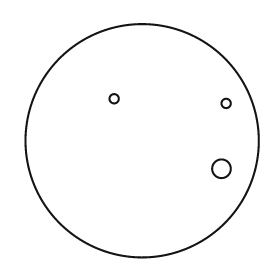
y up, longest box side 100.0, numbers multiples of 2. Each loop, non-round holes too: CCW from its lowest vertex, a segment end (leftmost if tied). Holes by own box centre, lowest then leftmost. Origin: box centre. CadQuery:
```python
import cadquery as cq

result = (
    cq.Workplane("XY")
    .moveTo(0.0, 0.0)
    .circle(50.0)
    .moveTo(34.0, -12.0)
    .circle(4.0)
    .moveTo(36.0, 16.0)
    .circle(2.0)
    .moveTo(-12.0, 18.0)
    .circle(2.0)
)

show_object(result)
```